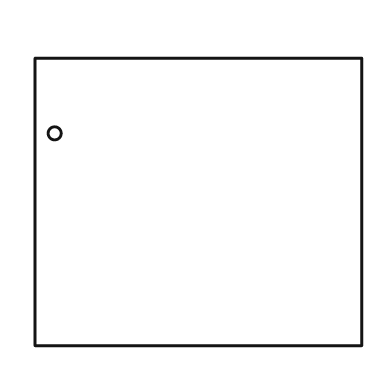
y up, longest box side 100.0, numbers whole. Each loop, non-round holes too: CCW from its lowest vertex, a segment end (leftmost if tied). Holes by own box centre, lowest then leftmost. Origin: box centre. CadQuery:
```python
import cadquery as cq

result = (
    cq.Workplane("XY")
    .moveTo(-50.0, -44.0)
    .lineTo(50.0, -44.0)
    .lineTo(50.0, 44.0)
    .lineTo(-50.0, 44.0)
    .close()
    .moveTo(-44.0, 21.0)
    .circle(2.0)
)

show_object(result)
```